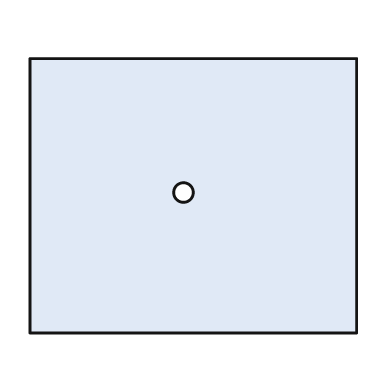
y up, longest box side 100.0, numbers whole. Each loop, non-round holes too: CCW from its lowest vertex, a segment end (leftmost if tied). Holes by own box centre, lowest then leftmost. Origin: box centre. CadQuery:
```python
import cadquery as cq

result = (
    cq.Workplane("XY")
    .moveTo(-50.0, -42.0)
    .lineTo(50.0, -42.0)
    .lineTo(50.0, 42.0)
    .lineTo(-50.0, 42.0)
    .close()
    .moveTo(-3.0, 1.0)
    .circle(3.0)
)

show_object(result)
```